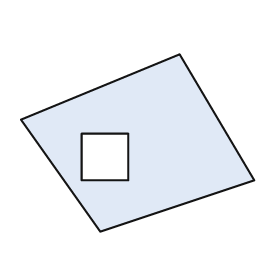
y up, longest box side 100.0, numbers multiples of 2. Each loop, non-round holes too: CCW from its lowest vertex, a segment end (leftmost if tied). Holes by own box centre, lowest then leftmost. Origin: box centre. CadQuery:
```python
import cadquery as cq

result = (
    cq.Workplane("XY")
    .moveTo(-16.0, -38.0)
    .lineTo(50.0, -16.0)
    .lineTo(18.0, 38.0)
    .lineTo(-50.0, 10.0)
    .close()
    .moveTo(-24.0, -16.0)
    .lineTo(-4.0, -16.0)
    .lineTo(-4.0, 4.0)
    .lineTo(-24.0, 4.0)
    .close()
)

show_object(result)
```